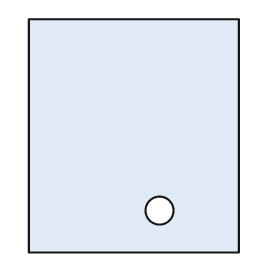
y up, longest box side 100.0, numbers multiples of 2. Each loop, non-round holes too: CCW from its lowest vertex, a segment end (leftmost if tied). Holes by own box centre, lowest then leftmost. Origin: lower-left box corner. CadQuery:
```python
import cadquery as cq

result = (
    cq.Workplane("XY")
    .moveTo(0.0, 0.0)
    .lineTo(90.0, 0.0)
    .lineTo(90.0, 100.0)
    .lineTo(0.0, 100.0)
    .close()
    .moveTo(56.0, 18.0)
    .circle(6.0)
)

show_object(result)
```